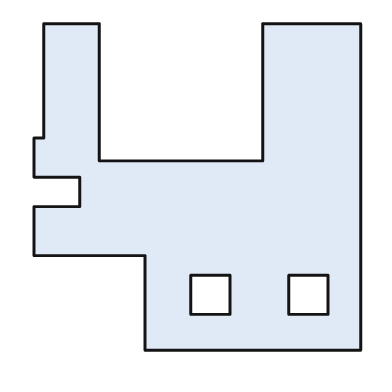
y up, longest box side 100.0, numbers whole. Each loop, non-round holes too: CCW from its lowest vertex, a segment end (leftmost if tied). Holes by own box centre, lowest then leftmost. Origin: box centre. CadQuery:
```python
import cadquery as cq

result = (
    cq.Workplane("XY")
    .moveTo(-16.0, -50.0)
    .lineTo(50.0, -50.0)
    .lineTo(50.0, 50.0)
    .lineTo(20.0, 50.0)
    .lineTo(20.0, 8.0)
    .lineTo(-30.0, 8.0)
    .lineTo(-30.0, 50.0)
    .lineTo(-47.0, 50.0)
    .lineTo(-47.0, 15.0)
    .lineTo(-50.0, 15.0)
    .lineTo(-50.0, 3.0)
    .lineTo(-36.0, 3.0)
    .lineTo(-36.0, -6.0)
    .lineTo(-50.0, -6.0)
    .lineTo(-50.0, -21.0)
    .lineTo(-16.0, -21.0)
    .close()
    .moveTo(-2.0, -39.0)
    .lineTo(10.0, -39.0)
    .lineTo(10.0, -27.0)
    .lineTo(-2.0, -27.0)
    .close()
    .moveTo(28.0, -39.0)
    .lineTo(40.0, -39.0)
    .lineTo(40.0, -27.0)
    .lineTo(28.0, -27.0)
    .close()
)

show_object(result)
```